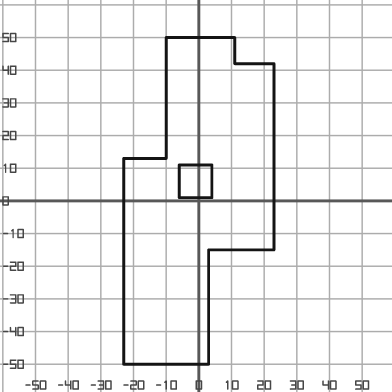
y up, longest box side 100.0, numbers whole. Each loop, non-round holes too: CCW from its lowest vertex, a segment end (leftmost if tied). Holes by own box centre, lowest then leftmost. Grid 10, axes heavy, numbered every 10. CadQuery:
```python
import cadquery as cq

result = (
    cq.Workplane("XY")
    .moveTo(-23.0, -50.0)
    .lineTo(3.0, -50.0)
    .lineTo(3.0, -15.0)
    .lineTo(23.0, -15.0)
    .lineTo(23.0, 42.0)
    .lineTo(11.0, 42.0)
    .lineTo(11.0, 50.0)
    .lineTo(-10.0, 50.0)
    .lineTo(-10.0, 13.0)
    .lineTo(-23.0, 13.0)
    .close()
    .moveTo(-6.0, 1.0)
    .lineTo(4.0, 1.0)
    .lineTo(4.0, 11.0)
    .lineTo(-6.0, 11.0)
    .close()
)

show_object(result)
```